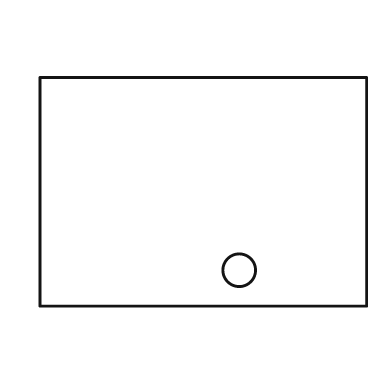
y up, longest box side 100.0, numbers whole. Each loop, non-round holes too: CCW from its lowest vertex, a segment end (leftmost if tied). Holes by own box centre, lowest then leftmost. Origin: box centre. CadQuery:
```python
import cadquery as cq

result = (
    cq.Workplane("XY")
    .moveTo(-50.0, -35.0)
    .lineTo(50.0, -35.0)
    .lineTo(50.0, 35.0)
    .lineTo(-50.0, 35.0)
    .close()
    .moveTo(11.0, -24.0)
    .circle(5.0)
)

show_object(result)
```